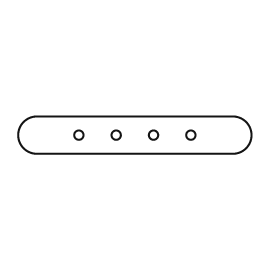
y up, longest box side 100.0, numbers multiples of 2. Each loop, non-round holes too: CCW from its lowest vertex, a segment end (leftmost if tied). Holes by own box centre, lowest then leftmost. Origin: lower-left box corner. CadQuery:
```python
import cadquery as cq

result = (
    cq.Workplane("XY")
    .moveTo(8.0, 0.0)
    .lineTo(92.0, 0.0)
    .threePointArc((100.0, 8.0), (92.0, 16.0))
    .lineTo(8.0, 16.0)
    .threePointArc((0.0, 8.0), (8.0, 0.0))
    .close()
    .moveTo(26.0, 8.0)
    .circle(2.0)
    .moveTo(42.0, 8.0)
    .circle(2.0)
    .moveTo(58.0, 8.0)
    .circle(2.0)
    .moveTo(74.0, 8.0)
    .circle(2.0)
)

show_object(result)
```